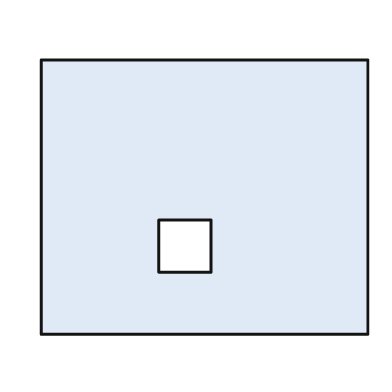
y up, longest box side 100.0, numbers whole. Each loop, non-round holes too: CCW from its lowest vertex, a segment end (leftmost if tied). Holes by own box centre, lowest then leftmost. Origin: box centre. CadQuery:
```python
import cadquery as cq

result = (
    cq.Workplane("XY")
    .moveTo(-50.0, -42.0)
    .lineTo(50.0, -42.0)
    .lineTo(50.0, 42.0)
    .lineTo(-50.0, 42.0)
    .close()
    .moveTo(-14.0, -23.0)
    .lineTo(2.0, -23.0)
    .lineTo(2.0, -7.0)
    .lineTo(-14.0, -7.0)
    .close()
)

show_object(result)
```